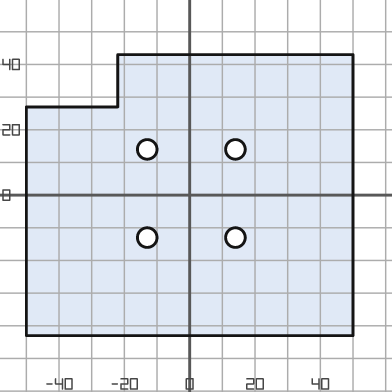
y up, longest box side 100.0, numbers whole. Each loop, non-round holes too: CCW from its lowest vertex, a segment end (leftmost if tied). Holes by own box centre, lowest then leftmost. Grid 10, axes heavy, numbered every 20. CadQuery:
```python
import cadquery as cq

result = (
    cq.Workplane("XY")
    .moveTo(-50.0, -43.0)
    .lineTo(50.0, -43.0)
    .lineTo(50.0, 43.0)
    .lineTo(-22.0, 43.0)
    .lineTo(-22.0, 27.0)
    .lineTo(-50.0, 27.0)
    .close()
    .moveTo(-13.0, -13.0)
    .circle(3.0)
    .moveTo(14.0, -13.0)
    .circle(3.0)
    .moveTo(-13.0, 14.0)
    .circle(3.0)
    .moveTo(14.0, 14.0)
    .circle(3.0)
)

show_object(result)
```